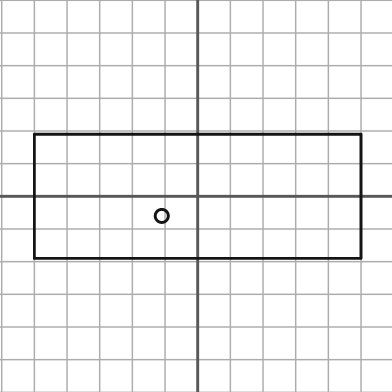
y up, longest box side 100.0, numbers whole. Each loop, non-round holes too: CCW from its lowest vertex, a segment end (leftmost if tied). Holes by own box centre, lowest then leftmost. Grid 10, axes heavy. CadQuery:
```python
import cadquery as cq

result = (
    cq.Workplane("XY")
    .moveTo(-50.0, -19.0)
    .lineTo(50.0, -19.0)
    .lineTo(50.0, 19.0)
    .lineTo(-50.0, 19.0)
    .close()
    .moveTo(-11.0, -6.0)
    .circle(2.0)
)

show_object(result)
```